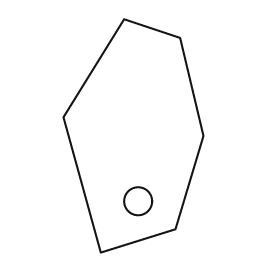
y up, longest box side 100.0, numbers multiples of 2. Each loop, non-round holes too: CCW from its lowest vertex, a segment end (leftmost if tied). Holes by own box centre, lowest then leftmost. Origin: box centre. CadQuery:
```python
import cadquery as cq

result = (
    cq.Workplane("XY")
    .moveTo(-14.0, -50.0)
    .lineTo(18.0, -40.0)
    .lineTo(30.0, 0.0)
    .lineTo(20.0, 42.0)
    .lineTo(-4.0, 50.0)
    .lineTo(-30.0, 8.0)
    .close()
    .moveTo(2.0, -28.0)
    .circle(6.0)
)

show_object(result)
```